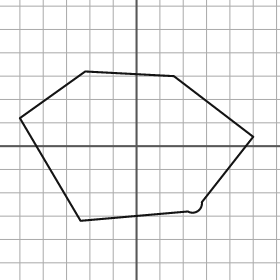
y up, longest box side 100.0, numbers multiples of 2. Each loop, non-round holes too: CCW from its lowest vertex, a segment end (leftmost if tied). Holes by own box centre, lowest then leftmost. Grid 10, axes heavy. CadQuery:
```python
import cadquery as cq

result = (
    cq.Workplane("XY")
    .moveTo(-24.0, -32.0)
    .lineTo(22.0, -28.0)
    .threePointArc((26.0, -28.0), (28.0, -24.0))
    .lineTo(50.0, 4.0)
    .lineTo(16.0, 30.0)
    .lineTo(-22.0, 32.0)
    .lineTo(-50.0, 12.0)
    .close()
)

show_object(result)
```